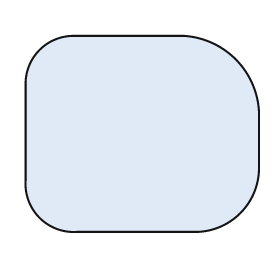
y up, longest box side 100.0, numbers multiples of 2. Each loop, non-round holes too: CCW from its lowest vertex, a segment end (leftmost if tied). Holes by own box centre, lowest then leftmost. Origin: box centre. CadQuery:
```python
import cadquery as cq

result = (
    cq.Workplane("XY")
    .moveTo(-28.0, -42.0)
    .lineTo(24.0, -42.0)
    .threePointArc((42.0, -34.0), (50.0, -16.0))
    .lineTo(50.0, 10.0)
    .threePointArc((40.0, 32.0), (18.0, 42.0))
    .lineTo(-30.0, 42.0)
    .threePointArc((-44.0, 36.0), (-50.0, 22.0))
    .lineTo(-50.0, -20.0)
    .threePointArc((-44.0, -36.0), (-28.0, -42.0))
    .close()
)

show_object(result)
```